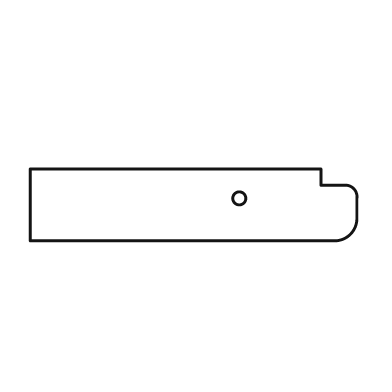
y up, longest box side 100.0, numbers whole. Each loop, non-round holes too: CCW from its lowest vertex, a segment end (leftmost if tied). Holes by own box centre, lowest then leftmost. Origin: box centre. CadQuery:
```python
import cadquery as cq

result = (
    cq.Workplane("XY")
    .moveTo(-50.0, -11.0)
    .lineTo(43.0, -11.0)
    .threePointArc((48.0, -9.0), (50.0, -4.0))
    .lineTo(50.0, 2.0)
    .threePointArc((49.0, 5.0), (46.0, 6.0))
    .lineTo(39.0, 6.0)
    .lineTo(39.0, 11.0)
    .lineTo(-50.0, 11.0)
    .close()
    .moveTo(14.0, 2.0)
    .circle(2.0)
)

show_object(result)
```